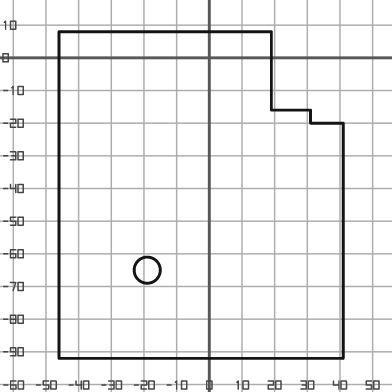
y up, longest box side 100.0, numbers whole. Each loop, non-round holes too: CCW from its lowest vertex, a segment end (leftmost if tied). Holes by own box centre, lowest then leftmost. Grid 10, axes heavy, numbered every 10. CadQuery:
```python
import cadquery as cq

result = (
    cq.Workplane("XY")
    .moveTo(-46.0, -92.0)
    .lineTo(41.0, -92.0)
    .lineTo(41.0, -20.0)
    .lineTo(31.0, -20.0)
    .lineTo(31.0, -16.0)
    .lineTo(19.0, -16.0)
    .lineTo(19.0, 8.0)
    .lineTo(-46.0, 8.0)
    .close()
    .moveTo(-19.0, -65.0)
    .circle(4.0)
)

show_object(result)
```